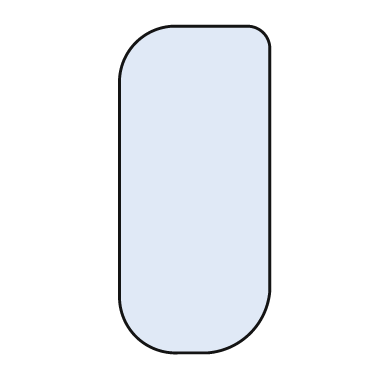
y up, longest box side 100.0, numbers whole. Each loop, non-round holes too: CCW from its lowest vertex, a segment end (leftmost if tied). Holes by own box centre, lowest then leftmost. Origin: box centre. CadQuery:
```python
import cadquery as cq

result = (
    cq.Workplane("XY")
    .moveTo(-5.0, -50.0)
    .lineTo(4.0, -50.0)
    .threePointArc((17.0, -44.0), (23.0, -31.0))
    .lineTo(23.0, 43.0)
    .threePointArc((21.0, 48.0), (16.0, 50.0))
    .lineTo(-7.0, 50.0)
    .threePointArc((-18.0, 45.0), (-23.0, 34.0))
    .lineTo(-23.0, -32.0)
    .threePointArc((-18.0, -45.0), (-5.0, -50.0))
    .close()
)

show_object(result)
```